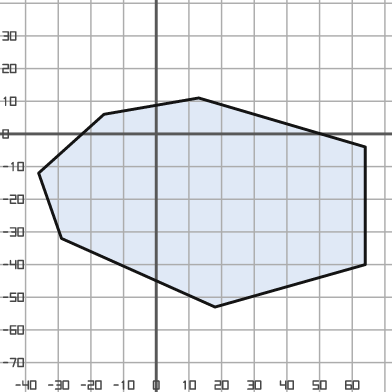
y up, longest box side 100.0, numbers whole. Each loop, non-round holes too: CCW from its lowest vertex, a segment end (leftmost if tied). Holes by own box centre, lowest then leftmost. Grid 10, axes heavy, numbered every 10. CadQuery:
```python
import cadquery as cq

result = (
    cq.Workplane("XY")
    .moveTo(18.0, -53.0)
    .lineTo(64.0, -40.0)
    .lineTo(64.0, -4.0)
    .lineTo(13.0, 11.0)
    .lineTo(-16.0, 6.0)
    .lineTo(-36.0, -12.0)
    .lineTo(-29.0, -32.0)
    .close()
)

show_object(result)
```